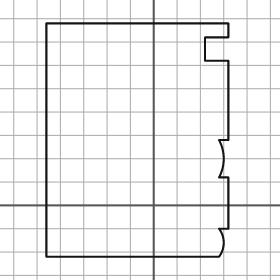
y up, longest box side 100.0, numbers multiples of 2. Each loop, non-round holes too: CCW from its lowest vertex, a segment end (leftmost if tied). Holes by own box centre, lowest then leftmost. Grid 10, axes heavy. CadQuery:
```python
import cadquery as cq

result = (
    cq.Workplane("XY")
    .moveTo(-46.0, -22.0)
    .lineTo(28.0, -22.0)
    .threePointArc((30.0, -16.0), (28.0, -10.0))
    .lineTo(32.0, -10.0)
    .lineTo(32.0, 12.0)
    .lineTo(28.0, 12.0)
    .threePointArc((30.0, 20.0), (28.0, 28.0))
    .lineTo(32.0, 28.0)
    .lineTo(32.0, 62.0)
    .lineTo(22.0, 62.0)
    .lineTo(22.0, 72.0)
    .lineTo(32.0, 72.0)
    .lineTo(32.0, 78.0)
    .lineTo(-46.0, 78.0)
    .close()
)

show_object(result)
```